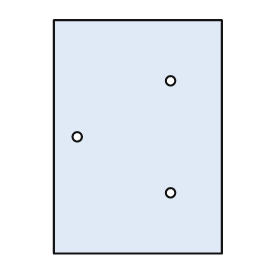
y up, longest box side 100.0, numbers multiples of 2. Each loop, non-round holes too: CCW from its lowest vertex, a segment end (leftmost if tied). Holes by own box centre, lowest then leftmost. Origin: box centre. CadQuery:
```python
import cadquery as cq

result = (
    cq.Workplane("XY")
    .moveTo(-36.0, -50.0)
    .lineTo(36.0, -50.0)
    .lineTo(36.0, 50.0)
    .lineTo(-36.0, 50.0)
    .close()
    .moveTo(14.0, -24.0)
    .circle(2.0)
    .moveTo(-26.0, 0.0)
    .circle(2.0)
    .moveTo(14.0, 24.0)
    .circle(2.0)
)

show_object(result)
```